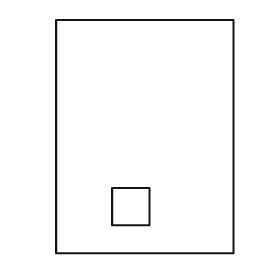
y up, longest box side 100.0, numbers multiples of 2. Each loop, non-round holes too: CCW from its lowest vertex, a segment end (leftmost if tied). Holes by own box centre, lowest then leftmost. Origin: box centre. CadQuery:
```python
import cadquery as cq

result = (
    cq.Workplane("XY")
    .moveTo(-38.0, -50.0)
    .lineTo(38.0, -50.0)
    .lineTo(38.0, 50.0)
    .lineTo(-38.0, 50.0)
    .close()
    .moveTo(-14.0, -38.0)
    .lineTo(2.0, -38.0)
    .lineTo(2.0, -22.0)
    .lineTo(-14.0, -22.0)
    .close()
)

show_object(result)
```